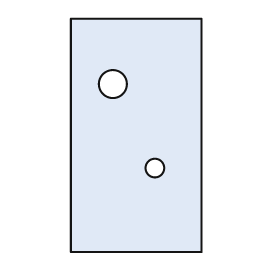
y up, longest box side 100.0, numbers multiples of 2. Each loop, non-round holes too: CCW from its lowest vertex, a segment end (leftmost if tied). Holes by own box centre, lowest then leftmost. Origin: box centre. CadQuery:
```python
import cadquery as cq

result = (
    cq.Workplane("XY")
    .moveTo(-28.0, -50.0)
    .lineTo(28.0, -50.0)
    .lineTo(28.0, 50.0)
    .lineTo(-28.0, 50.0)
    .close()
    .moveTo(8.0, -14.0)
    .circle(4.0)
    .moveTo(-10.0, 22.0)
    .circle(6.0)
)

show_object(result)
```